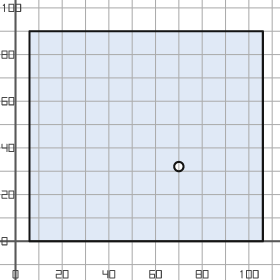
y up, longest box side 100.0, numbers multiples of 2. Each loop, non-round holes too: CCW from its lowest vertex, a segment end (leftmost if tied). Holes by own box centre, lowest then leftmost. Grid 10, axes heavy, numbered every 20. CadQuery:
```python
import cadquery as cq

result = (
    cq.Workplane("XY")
    .moveTo(6.0, 0.0)
    .lineTo(106.0, 0.0)
    .lineTo(106.0, 90.0)
    .lineTo(6.0, 90.0)
    .close()
    .moveTo(70.0, 32.0)
    .circle(2.0)
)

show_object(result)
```